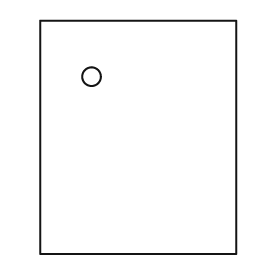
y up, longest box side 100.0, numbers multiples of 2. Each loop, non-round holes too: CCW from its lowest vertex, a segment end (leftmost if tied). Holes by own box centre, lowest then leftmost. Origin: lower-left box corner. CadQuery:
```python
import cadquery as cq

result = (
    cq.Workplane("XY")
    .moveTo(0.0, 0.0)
    .lineTo(84.0, 0.0)
    .lineTo(84.0, 100.0)
    .lineTo(0.0, 100.0)
    .close()
    .moveTo(22.0, 76.0)
    .circle(4.0)
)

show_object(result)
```